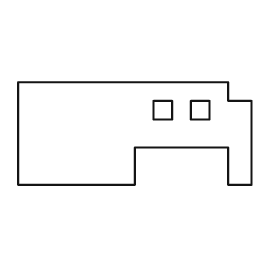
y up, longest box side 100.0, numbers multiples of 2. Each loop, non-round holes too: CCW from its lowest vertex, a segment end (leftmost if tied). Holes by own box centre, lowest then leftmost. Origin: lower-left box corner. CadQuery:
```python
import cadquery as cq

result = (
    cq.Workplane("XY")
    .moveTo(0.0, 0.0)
    .lineTo(50.0, 0.0)
    .lineTo(50.0, 16.0)
    .lineTo(90.0, 16.0)
    .lineTo(90.0, 0.0)
    .lineTo(100.0, 0.0)
    .lineTo(100.0, 36.0)
    .lineTo(90.0, 36.0)
    .lineTo(90.0, 44.0)
    .lineTo(0.0, 44.0)
    .close()
    .moveTo(58.0, 28.0)
    .lineTo(66.0, 28.0)
    .lineTo(66.0, 36.0)
    .lineTo(58.0, 36.0)
    .close()
    .moveTo(74.0, 28.0)
    .lineTo(82.0, 28.0)
    .lineTo(82.0, 36.0)
    .lineTo(74.0, 36.0)
    .close()
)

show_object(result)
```